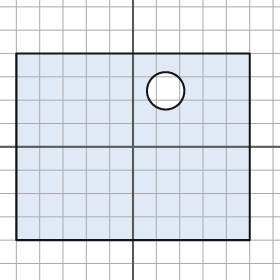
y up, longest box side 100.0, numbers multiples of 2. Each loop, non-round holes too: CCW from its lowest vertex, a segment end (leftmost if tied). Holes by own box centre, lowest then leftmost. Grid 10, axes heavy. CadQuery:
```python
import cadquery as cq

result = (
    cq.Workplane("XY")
    .moveTo(-50.0, -40.0)
    .lineTo(50.0, -40.0)
    .lineTo(50.0, 40.0)
    .lineTo(-50.0, 40.0)
    .close()
    .moveTo(14.0, 24.0)
    .circle(8.0)
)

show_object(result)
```